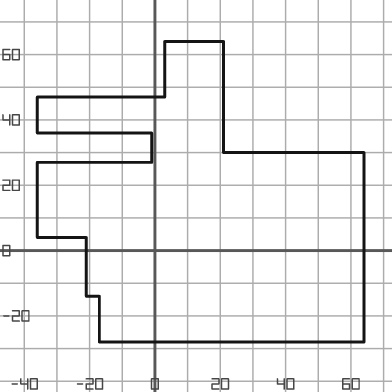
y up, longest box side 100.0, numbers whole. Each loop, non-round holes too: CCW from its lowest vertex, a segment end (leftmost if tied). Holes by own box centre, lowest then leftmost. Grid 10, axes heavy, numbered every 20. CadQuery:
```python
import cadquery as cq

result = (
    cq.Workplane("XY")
    .moveTo(-17.0, -28.0)
    .lineTo(64.0, -28.0)
    .lineTo(64.0, 30.0)
    .lineTo(21.0, 30.0)
    .lineTo(21.0, 64.0)
    .lineTo(3.0, 64.0)
    .lineTo(3.0, 47.0)
    .lineTo(-36.0, 47.0)
    .lineTo(-36.0, 36.0)
    .lineTo(-1.0, 36.0)
    .lineTo(-1.0, 27.0)
    .lineTo(-36.0, 27.0)
    .lineTo(-36.0, 4.0)
    .lineTo(-21.0, 4.0)
    .lineTo(-21.0, -14.0)
    .lineTo(-17.0, -14.0)
    .close()
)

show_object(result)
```